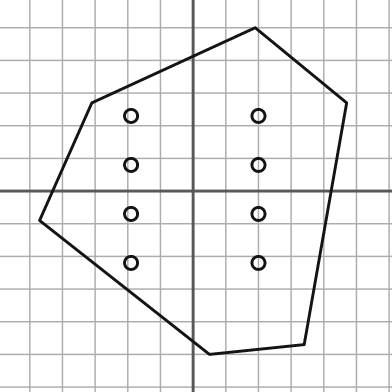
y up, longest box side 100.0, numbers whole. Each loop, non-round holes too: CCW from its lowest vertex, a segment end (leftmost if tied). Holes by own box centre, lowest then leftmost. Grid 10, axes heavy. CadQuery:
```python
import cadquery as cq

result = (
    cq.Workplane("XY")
    .moveTo(5.0, -50.0)
    .lineTo(34.0, -47.0)
    .lineTo(47.0, 27.0)
    .lineTo(19.0, 50.0)
    .lineTo(-31.0, 27.0)
    .lineTo(-47.0, -9.0)
    .close()
    .moveTo(-19.0, -22.0)
    .circle(2.0)
    .moveTo(20.0, -22.0)
    .circle(2.0)
    .moveTo(-19.0, -7.0)
    .circle(2.0)
    .moveTo(20.0, -7.0)
    .circle(2.0)
    .moveTo(-19.0, 8.0)
    .circle(2.0)
    .moveTo(20.0, 8.0)
    .circle(2.0)
    .moveTo(-19.0, 23.0)
    .circle(2.0)
    .moveTo(20.0, 23.0)
    .circle(2.0)
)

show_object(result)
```